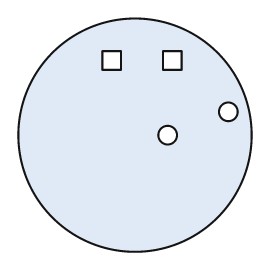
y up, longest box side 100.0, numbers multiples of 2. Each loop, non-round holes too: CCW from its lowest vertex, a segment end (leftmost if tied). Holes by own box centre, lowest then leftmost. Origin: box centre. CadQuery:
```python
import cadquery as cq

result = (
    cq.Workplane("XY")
    .moveTo(0.0, 0.0)
    .circle(50.0)
    .moveTo(14.0, 0.0)
    .circle(4.0)
    .moveTo(40.0, 10.0)
    .circle(4.0)
    .moveTo(-14.0, 28.0)
    .lineTo(-6.0, 28.0)
    .lineTo(-6.0, 36.0)
    .lineTo(-14.0, 36.0)
    .close()
    .moveTo(12.0, 28.0)
    .lineTo(20.0, 28.0)
    .lineTo(20.0, 36.0)
    .lineTo(12.0, 36.0)
    .close()
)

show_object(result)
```